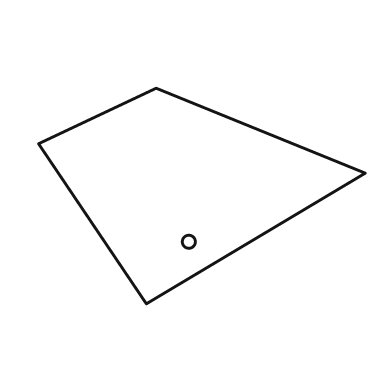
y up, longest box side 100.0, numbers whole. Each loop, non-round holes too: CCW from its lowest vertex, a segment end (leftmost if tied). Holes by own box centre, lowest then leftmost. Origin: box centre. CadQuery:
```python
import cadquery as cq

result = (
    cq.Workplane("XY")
    .moveTo(-17.0, -33.0)
    .lineTo(50.0, 7.0)
    .lineTo(-14.0, 33.0)
    .lineTo(-50.0, 16.0)
    .close()
    .moveTo(-4.0, -14.0)
    .circle(2.0)
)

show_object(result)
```